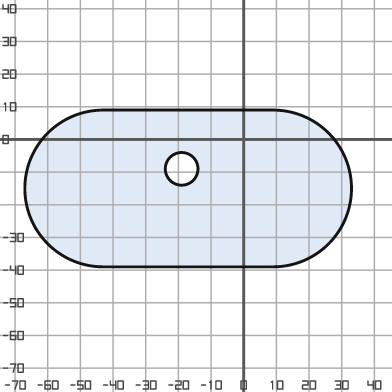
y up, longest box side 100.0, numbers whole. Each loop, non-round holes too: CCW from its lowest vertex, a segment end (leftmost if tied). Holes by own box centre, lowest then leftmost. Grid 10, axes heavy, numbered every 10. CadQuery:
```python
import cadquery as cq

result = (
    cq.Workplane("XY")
    .moveTo(-43.0, -39.0)
    .lineTo(9.0, -39.0)
    .threePointArc((33.0, -15.0), (9.0, 9.0))
    .lineTo(-43.0, 9.0)
    .threePointArc((-67.0, -15.0), (-43.0, -39.0))
    .close()
    .moveTo(-19.0, -9.0)
    .circle(5.0)
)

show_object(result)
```